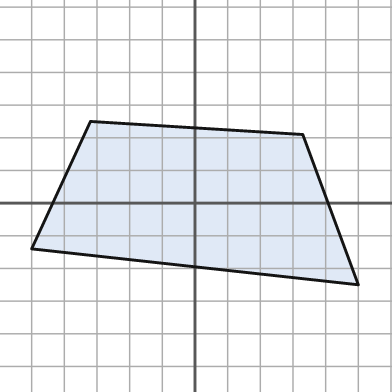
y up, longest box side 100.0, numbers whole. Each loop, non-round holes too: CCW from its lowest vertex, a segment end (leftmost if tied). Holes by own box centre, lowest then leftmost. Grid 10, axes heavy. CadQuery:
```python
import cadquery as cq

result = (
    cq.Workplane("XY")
    .moveTo(50.0, -25.0)
    .lineTo(33.0, 21.0)
    .lineTo(-32.0, 25.0)
    .lineTo(-50.0, -14.0)
    .close()
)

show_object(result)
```